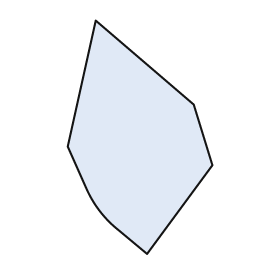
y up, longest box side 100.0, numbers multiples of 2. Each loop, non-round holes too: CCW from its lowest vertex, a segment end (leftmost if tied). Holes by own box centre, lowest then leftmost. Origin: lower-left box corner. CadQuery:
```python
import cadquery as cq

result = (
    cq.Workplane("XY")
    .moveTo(34.0, 0.0)
    .lineTo(62.0, 38.0)
    .lineTo(54.0, 64.0)
    .lineTo(12.0, 100.0)
    .lineTo(0.0, 46.0)
    .lineTo(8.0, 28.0)
    .threePointArc((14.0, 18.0), (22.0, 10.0))
    .close()
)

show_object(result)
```